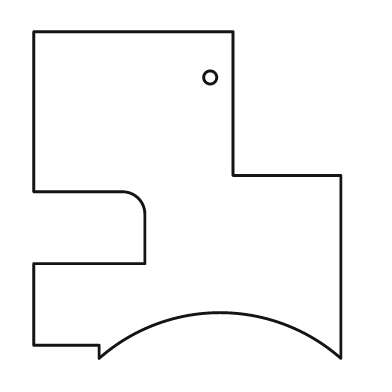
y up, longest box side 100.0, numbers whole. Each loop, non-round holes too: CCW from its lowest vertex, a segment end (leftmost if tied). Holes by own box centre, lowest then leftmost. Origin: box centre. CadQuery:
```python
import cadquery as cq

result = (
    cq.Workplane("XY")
    .moveTo(-27.0, -50.0)
    .threePointArc((10.0, -36.0), (47.0, -50.0))
    .lineTo(47.0, 6.0)
    .lineTo(14.0, 6.0)
    .lineTo(14.0, 50.0)
    .lineTo(-47.0, 50.0)
    .lineTo(-47.0, 1.0)
    .lineTo(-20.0, 1.0)
    .threePointArc((-15.0, -1.0), (-13.0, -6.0))
    .lineTo(-13.0, -21.0)
    .lineTo(-47.0, -21.0)
    .lineTo(-47.0, -46.0)
    .lineTo(-27.0, -46.0)
    .close()
    .moveTo(7.0, 36.0)
    .circle(2.0)
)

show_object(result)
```